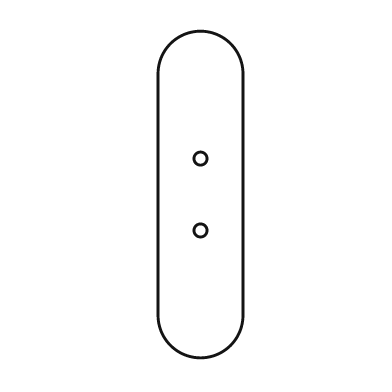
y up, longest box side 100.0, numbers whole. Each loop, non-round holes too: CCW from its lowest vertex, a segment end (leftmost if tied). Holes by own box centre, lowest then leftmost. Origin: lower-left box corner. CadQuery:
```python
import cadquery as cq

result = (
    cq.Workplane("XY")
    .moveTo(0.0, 13.0)
    .threePointArc((13.0, 0.0), (26.0, 13.0))
    .lineTo(26.0, 87.0)
    .threePointArc((13.0, 100.0), (0.0, 87.0))
    .close()
    .moveTo(13.0, 39.0)
    .circle(2.0)
    .moveTo(13.0, 61.0)
    .circle(2.0)
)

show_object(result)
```